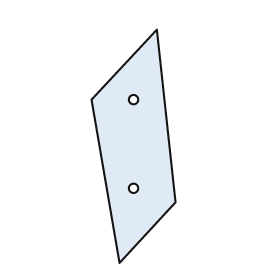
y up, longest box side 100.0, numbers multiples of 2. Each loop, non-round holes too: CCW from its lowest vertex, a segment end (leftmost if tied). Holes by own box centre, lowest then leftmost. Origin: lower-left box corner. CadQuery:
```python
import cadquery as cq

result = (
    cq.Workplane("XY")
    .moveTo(12.0, 0.0)
    .lineTo(36.0, 26.0)
    .lineTo(28.0, 100.0)
    .lineTo(0.0, 70.0)
    .close()
    .moveTo(18.0, 32.0)
    .circle(2.0)
    .moveTo(18.0, 70.0)
    .circle(2.0)
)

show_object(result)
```